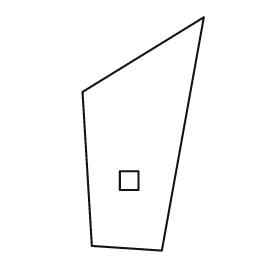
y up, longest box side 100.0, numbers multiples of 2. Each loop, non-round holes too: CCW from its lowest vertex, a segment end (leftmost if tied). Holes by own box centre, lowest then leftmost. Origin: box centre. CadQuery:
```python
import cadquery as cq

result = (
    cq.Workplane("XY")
    .moveTo(8.0, -50.0)
    .lineTo(26.0, 50.0)
    .lineTo(-26.0, 18.0)
    .lineTo(-22.0, -48.0)
    .close()
    .moveTo(-10.0, -24.0)
    .lineTo(-2.0, -24.0)
    .lineTo(-2.0, -16.0)
    .lineTo(-10.0, -16.0)
    .close()
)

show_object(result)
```